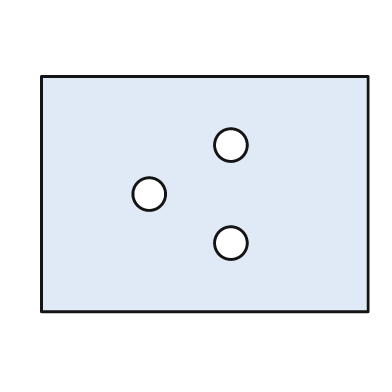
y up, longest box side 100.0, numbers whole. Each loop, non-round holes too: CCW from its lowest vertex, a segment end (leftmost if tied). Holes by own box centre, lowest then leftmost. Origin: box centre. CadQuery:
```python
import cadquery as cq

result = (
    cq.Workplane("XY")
    .moveTo(-50.0, -36.0)
    .lineTo(50.0, -36.0)
    .lineTo(50.0, 36.0)
    .lineTo(-50.0, 36.0)
    .close()
    .moveTo(8.0, -15.0)
    .circle(5.0)
    .moveTo(-17.0, 0.0)
    .circle(5.0)
    .moveTo(8.0, 15.0)
    .circle(5.0)
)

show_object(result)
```